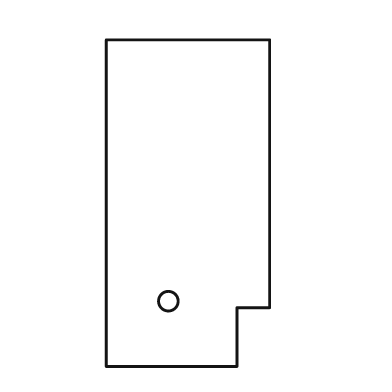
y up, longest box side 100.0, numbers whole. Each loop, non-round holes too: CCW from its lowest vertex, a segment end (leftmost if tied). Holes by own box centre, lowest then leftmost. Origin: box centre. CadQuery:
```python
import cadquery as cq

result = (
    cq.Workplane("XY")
    .moveTo(-25.0, -50.0)
    .lineTo(15.0, -50.0)
    .lineTo(15.0, -32.0)
    .lineTo(25.0, -32.0)
    .lineTo(25.0, 50.0)
    .lineTo(-25.0, 50.0)
    .close()
    .moveTo(-6.0, -30.0)
    .circle(3.0)
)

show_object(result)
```